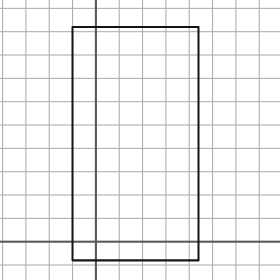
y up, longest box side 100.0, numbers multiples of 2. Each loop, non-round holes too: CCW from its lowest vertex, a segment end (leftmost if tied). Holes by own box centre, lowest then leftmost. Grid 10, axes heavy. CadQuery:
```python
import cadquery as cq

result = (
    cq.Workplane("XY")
    .moveTo(-10.0, -8.0)
    .lineTo(44.0, -8.0)
    .lineTo(44.0, 92.0)
    .lineTo(-10.0, 92.0)
    .close()
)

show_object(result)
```